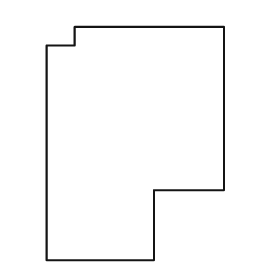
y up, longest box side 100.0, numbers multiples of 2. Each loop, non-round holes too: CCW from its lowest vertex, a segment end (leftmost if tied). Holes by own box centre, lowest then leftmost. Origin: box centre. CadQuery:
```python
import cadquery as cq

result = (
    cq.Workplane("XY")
    .moveTo(-38.0, -50.0)
    .lineTo(8.0, -50.0)
    .lineTo(8.0, -20.0)
    .lineTo(38.0, -20.0)
    .lineTo(38.0, 50.0)
    .lineTo(-26.0, 50.0)
    .lineTo(-26.0, 42.0)
    .lineTo(-38.0, 42.0)
    .close()
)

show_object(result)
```